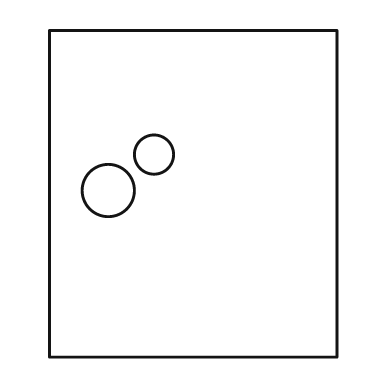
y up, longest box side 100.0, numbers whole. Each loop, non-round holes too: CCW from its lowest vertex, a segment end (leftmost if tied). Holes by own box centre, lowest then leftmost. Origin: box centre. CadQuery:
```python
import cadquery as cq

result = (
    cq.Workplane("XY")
    .moveTo(-44.0, -50.0)
    .lineTo(44.0, -50.0)
    .lineTo(44.0, 50.0)
    .lineTo(-44.0, 50.0)
    .close()
    .moveTo(-26.0, 1.0)
    .circle(8.0)
    .moveTo(-12.0, 12.0)
    .circle(6.0)
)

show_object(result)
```